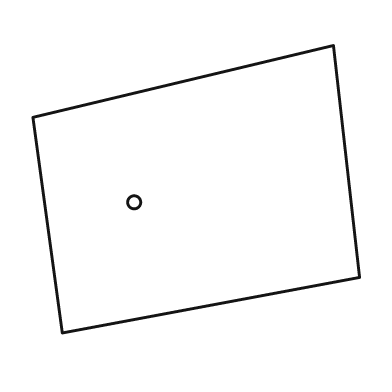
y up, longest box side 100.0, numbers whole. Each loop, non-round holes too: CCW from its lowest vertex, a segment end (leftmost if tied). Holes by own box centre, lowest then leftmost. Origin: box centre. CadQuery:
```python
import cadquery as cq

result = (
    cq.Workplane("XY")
    .moveTo(-41.0, -44.0)
    .lineTo(50.0, -27.0)
    .lineTo(42.0, 44.0)
    .lineTo(-50.0, 22.0)
    .close()
    .moveTo(-19.0, -4.0)
    .circle(2.0)
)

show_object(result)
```